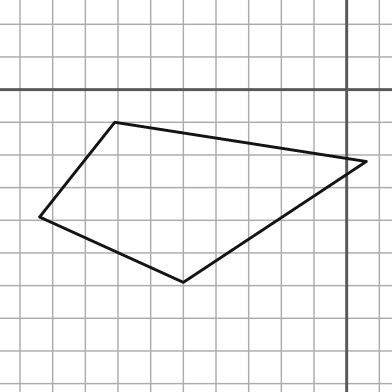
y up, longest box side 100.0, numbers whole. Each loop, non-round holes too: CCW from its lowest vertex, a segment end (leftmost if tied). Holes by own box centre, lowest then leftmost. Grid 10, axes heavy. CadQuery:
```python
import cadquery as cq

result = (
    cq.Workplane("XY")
    .moveTo(-50.0, -59.0)
    .lineTo(6.0, -22.0)
    .lineTo(-71.0, -10.0)
    .lineTo(-94.0, -39.0)
    .close()
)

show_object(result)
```